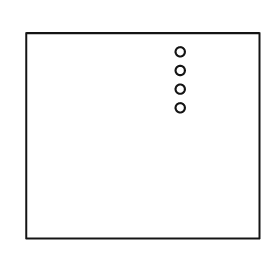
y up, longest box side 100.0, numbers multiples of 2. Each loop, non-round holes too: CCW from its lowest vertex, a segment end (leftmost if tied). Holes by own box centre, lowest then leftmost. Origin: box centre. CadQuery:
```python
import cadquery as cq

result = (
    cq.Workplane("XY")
    .moveTo(-50.0, -44.0)
    .lineTo(50.0, -44.0)
    .lineTo(50.0, 44.0)
    .lineTo(-50.0, 44.0)
    .close()
    .moveTo(16.0, 12.0)
    .circle(2.0)
    .moveTo(16.0, 20.0)
    .circle(2.0)
    .moveTo(16.0, 28.0)
    .circle(2.0)
    .moveTo(16.0, 36.0)
    .circle(2.0)
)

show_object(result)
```